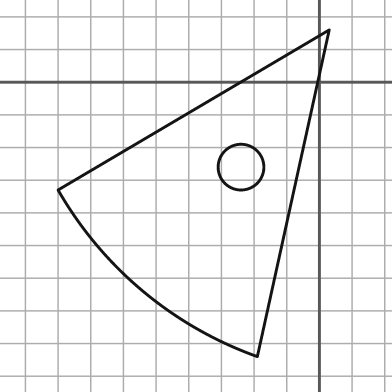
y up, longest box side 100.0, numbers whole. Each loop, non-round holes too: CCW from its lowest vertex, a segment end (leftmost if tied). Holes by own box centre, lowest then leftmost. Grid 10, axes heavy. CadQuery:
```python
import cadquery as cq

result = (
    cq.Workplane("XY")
    .moveTo(-19.0, -84.0)
    .lineTo(3.0, 16.0)
    .lineTo(-80.0, -33.0)
    .threePointArc((-54.0, -64.0), (-19.0, -84.0))
    .close()
    .moveTo(-24.0, -26.0)
    .circle(7.0)
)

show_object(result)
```